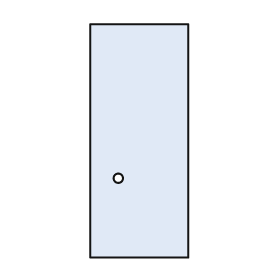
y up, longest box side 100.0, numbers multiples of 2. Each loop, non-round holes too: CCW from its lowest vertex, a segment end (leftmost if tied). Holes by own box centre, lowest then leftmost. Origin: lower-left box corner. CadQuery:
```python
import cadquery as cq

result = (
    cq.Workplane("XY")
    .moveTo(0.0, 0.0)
    .lineTo(42.0, 0.0)
    .lineTo(42.0, 100.0)
    .lineTo(0.0, 100.0)
    .close()
    .moveTo(12.0, 34.0)
    .circle(2.0)
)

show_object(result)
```